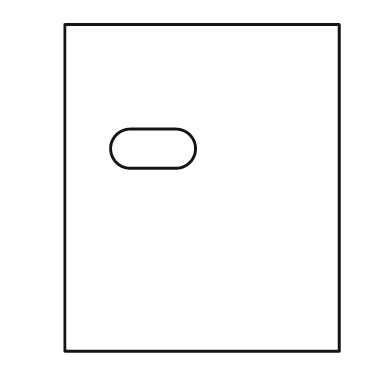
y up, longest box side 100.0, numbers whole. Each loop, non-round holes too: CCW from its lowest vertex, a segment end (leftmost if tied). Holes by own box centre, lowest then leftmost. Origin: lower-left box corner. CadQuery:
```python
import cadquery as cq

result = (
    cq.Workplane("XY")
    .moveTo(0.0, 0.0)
    .lineTo(84.0, 0.0)
    .lineTo(84.0, 100.0)
    .lineTo(0.0, 100.0)
    .close()
    .moveTo(20.0, 56.0)
    .lineTo(34.0, 56.0)
    .threePointArc((40.0, 62.0), (34.0, 68.0))
    .lineTo(20.0, 68.0)
    .threePointArc((14.0, 62.0), (20.0, 56.0))
    .close()
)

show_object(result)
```